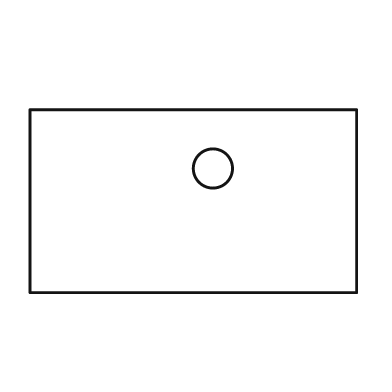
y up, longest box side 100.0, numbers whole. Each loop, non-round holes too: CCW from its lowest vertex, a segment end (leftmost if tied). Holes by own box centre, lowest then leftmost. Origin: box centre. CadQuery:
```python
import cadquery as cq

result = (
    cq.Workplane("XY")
    .moveTo(-50.0, -28.0)
    .lineTo(50.0, -28.0)
    .lineTo(50.0, 28.0)
    .lineTo(-50.0, 28.0)
    .close()
    .moveTo(6.0, 10.0)
    .circle(6.0)
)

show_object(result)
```